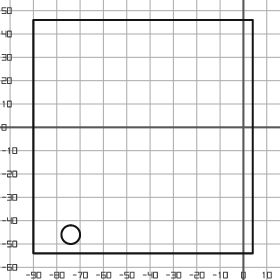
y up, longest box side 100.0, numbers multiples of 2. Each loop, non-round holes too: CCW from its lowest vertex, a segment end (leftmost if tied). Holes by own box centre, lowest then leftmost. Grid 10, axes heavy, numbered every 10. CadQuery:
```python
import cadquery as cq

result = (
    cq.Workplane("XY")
    .moveTo(-90.0, -54.0)
    .lineTo(4.0, -54.0)
    .lineTo(4.0, 46.0)
    .lineTo(-90.0, 46.0)
    .close()
    .moveTo(-74.0, -46.0)
    .circle(4.0)
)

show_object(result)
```